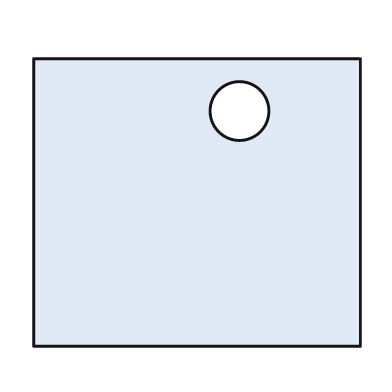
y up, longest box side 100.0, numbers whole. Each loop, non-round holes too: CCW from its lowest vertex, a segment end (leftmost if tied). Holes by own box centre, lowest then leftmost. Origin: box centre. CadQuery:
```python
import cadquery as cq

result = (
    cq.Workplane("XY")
    .moveTo(-50.0, -44.0)
    .lineTo(50.0, -44.0)
    .lineTo(50.0, 44.0)
    .lineTo(-50.0, 44.0)
    .close()
    .moveTo(13.0, 28.0)
    .circle(9.0)
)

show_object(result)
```